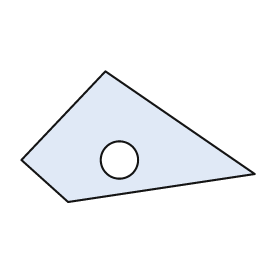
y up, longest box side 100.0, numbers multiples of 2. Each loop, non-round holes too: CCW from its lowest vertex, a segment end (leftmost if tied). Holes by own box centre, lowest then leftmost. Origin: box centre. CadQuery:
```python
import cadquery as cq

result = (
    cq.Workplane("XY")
    .moveTo(-30.0, -28.0)
    .lineTo(50.0, -16.0)
    .lineTo(-14.0, 28.0)
    .lineTo(-50.0, -10.0)
    .close()
    .moveTo(-8.0, -10.0)
    .circle(8.0)
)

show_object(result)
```